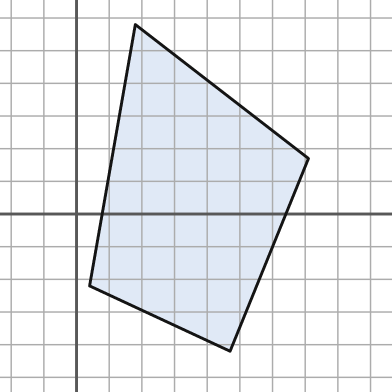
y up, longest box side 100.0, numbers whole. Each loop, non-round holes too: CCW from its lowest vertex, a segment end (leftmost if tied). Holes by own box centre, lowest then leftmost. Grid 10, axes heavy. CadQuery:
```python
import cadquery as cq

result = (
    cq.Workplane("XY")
    .moveTo(47.0, -42.0)
    .lineTo(71.0, 17.0)
    .lineTo(18.0, 58.0)
    .lineTo(4.0, -22.0)
    .close()
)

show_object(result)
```